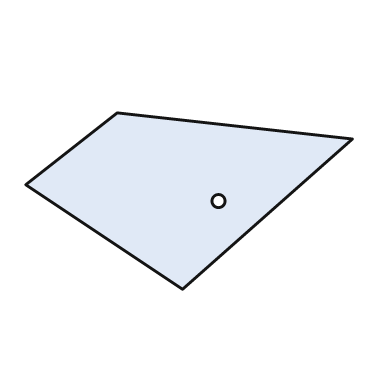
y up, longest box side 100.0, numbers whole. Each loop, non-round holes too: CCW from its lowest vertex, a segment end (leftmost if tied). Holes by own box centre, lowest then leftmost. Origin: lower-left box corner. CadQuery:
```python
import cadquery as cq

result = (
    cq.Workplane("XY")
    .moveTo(48.0, 0.0)
    .lineTo(100.0, 46.0)
    .lineTo(28.0, 54.0)
    .lineTo(0.0, 32.0)
    .close()
    .moveTo(59.0, 27.0)
    .circle(2.0)
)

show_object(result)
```